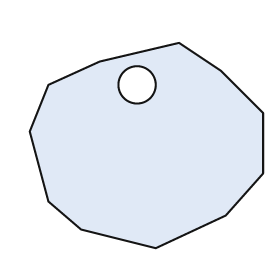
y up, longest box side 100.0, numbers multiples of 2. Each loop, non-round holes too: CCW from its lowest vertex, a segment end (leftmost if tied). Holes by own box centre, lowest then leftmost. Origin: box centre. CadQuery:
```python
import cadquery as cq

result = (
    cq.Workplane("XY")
    .moveTo(4.0, -44.0)
    .lineTo(34.0, -30.0)
    .lineTo(50.0, -12.0)
    .lineTo(50.0, 14.0)
    .lineTo(32.0, 32.0)
    .lineTo(14.0, 44.0)
    .lineTo(-20.0, 36.0)
    .lineTo(-42.0, 26.0)
    .lineTo(-50.0, 6.0)
    .lineTo(-42.0, -24.0)
    .lineTo(-28.0, -36.0)
    .close()
    .moveTo(-4.0, 26.0)
    .circle(8.0)
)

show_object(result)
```